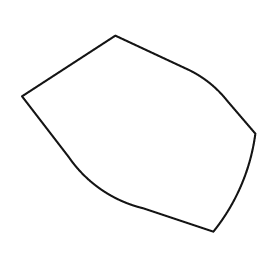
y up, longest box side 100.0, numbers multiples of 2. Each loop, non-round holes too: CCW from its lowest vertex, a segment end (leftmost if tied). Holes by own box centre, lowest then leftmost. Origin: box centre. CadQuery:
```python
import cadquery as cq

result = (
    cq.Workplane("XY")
    .moveTo(32.0, -42.0)
    .threePointArc((44.0, -22.0), (50.0, 0.0))
    .lineTo(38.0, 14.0)
    .threePointArc((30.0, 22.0), (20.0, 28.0))
    .lineTo(-10.0, 42.0)
    .lineTo(-50.0, 16.0)
    .lineTo(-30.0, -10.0)
    .threePointArc((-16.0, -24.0), (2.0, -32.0))
    .close()
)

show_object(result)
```